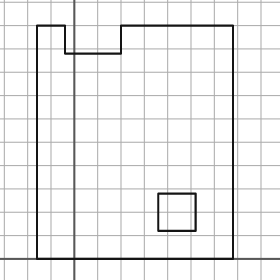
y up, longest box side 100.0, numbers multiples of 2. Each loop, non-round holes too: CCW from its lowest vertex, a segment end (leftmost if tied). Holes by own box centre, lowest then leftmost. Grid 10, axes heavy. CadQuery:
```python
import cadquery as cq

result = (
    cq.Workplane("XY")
    .moveTo(-16.0, 0.0)
    .lineTo(68.0, 0.0)
    .lineTo(68.0, 100.0)
    .lineTo(20.0, 100.0)
    .lineTo(20.0, 88.0)
    .lineTo(-4.0, 88.0)
    .lineTo(-4.0, 100.0)
    .lineTo(-16.0, 100.0)
    .close()
    .moveTo(36.0, 12.0)
    .lineTo(52.0, 12.0)
    .lineTo(52.0, 28.0)
    .lineTo(36.0, 28.0)
    .close()
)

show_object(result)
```